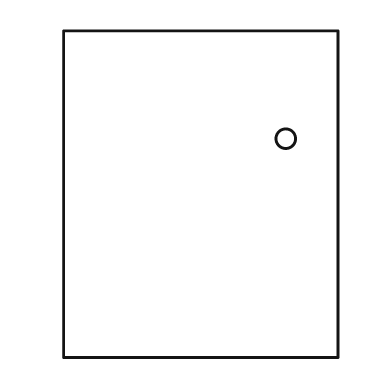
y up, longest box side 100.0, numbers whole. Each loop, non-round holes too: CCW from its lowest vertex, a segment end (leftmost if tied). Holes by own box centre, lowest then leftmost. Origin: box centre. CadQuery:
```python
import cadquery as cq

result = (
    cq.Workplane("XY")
    .moveTo(-42.0, -50.0)
    .lineTo(42.0, -50.0)
    .lineTo(42.0, 50.0)
    .lineTo(-42.0, 50.0)
    .close()
    .moveTo(26.0, 17.0)
    .circle(3.0)
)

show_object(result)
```